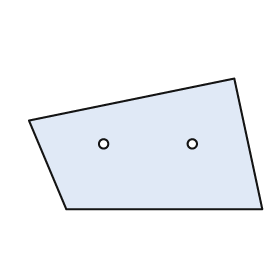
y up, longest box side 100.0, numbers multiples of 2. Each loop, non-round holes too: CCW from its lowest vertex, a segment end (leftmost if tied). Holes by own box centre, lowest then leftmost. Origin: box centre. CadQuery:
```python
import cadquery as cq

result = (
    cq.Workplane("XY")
    .moveTo(-34.0, -28.0)
    .lineTo(50.0, -28.0)
    .lineTo(38.0, 28.0)
    .lineTo(-50.0, 10.0)
    .close()
    .moveTo(-18.0, 0.0)
    .circle(2.0)
    .moveTo(20.0, 0.0)
    .circle(2.0)
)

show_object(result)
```